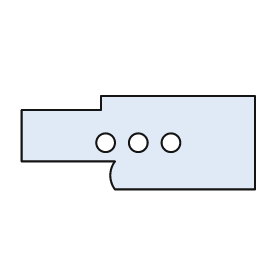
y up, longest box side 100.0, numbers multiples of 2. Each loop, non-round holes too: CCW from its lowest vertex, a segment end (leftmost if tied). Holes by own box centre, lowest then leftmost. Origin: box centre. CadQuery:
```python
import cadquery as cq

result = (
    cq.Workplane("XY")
    .moveTo(-10.0, -20.0)
    .lineTo(50.0, -20.0)
    .lineTo(50.0, 20.0)
    .lineTo(-16.0, 20.0)
    .lineTo(-16.0, 14.0)
    .lineTo(-50.0, 14.0)
    .lineTo(-50.0, -8.0)
    .lineTo(-10.0, -8.0)
    .threePointArc((-12.0, -14.0), (-10.0, -20.0))
    .close()
    .moveTo(-14.0, 0.0)
    .circle(4.0)
    .moveTo(0.0, 0.0)
    .circle(4.0)
    .moveTo(14.0, 0.0)
    .circle(4.0)
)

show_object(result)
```